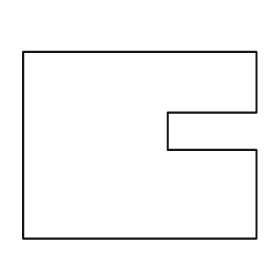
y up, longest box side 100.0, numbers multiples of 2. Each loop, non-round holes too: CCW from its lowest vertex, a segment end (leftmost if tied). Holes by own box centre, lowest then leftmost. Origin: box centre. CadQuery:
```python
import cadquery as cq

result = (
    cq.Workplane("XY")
    .moveTo(-50.0, -40.0)
    .lineTo(50.0, -40.0)
    .lineTo(50.0, -2.0)
    .lineTo(12.0, -2.0)
    .lineTo(12.0, 14.0)
    .lineTo(50.0, 14.0)
    .lineTo(50.0, 40.0)
    .lineTo(-50.0, 40.0)
    .close()
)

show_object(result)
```